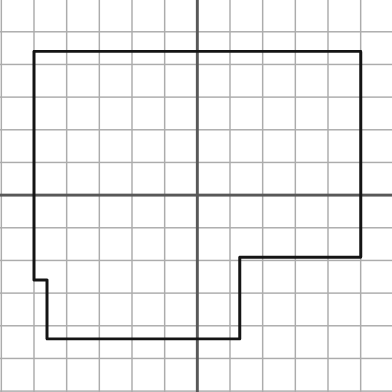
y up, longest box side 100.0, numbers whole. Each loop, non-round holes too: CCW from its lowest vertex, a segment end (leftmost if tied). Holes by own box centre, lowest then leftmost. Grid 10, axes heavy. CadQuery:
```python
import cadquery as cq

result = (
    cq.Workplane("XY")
    .moveTo(-46.0, -44.0)
    .lineTo(13.0, -44.0)
    .lineTo(13.0, -19.0)
    .lineTo(50.0, -19.0)
    .lineTo(50.0, 44.0)
    .lineTo(-50.0, 44.0)
    .lineTo(-50.0, -26.0)
    .lineTo(-46.0, -26.0)
    .close()
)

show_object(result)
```